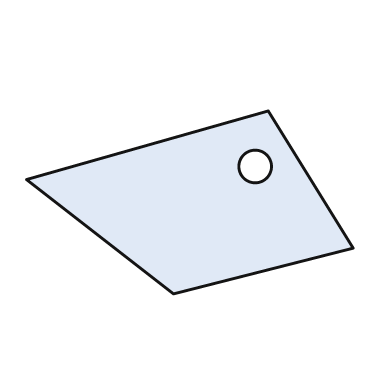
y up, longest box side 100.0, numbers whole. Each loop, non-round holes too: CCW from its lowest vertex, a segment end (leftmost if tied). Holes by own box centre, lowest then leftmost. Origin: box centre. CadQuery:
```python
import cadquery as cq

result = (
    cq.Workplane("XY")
    .moveTo(-5.0, -28.0)
    .lineTo(50.0, -14.0)
    .lineTo(24.0, 28.0)
    .lineTo(-50.0, 7.0)
    .close()
    .moveTo(20.0, 11.0)
    .circle(5.0)
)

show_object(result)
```